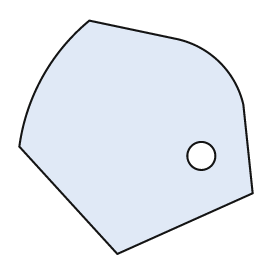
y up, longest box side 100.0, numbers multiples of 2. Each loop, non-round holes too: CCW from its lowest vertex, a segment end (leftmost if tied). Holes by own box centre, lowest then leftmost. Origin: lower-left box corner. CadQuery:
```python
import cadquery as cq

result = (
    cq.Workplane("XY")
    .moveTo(42.0, 0.0)
    .lineTo(100.0, 26.0)
    .lineTo(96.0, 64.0)
    .threePointArc((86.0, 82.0), (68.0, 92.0))
    .lineTo(30.0, 100.0)
    .threePointArc((10.0, 76.0), (0.0, 46.0))
    .close()
    .moveTo(78.0, 42.0)
    .circle(6.0)
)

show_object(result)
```